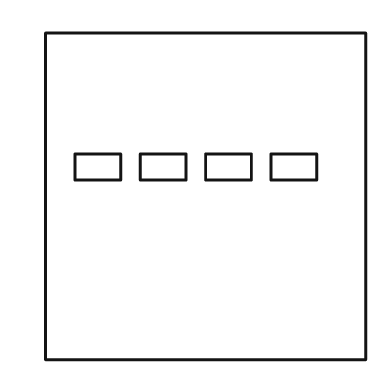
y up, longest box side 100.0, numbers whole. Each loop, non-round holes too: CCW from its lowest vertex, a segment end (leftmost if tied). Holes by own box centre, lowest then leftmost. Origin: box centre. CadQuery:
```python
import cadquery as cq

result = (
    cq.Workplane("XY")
    .moveTo(-49.0, -50.0)
    .lineTo(49.0, -50.0)
    .lineTo(49.0, 50.0)
    .lineTo(-49.0, 50.0)
    .close()
    .moveTo(-40.0, 5.0)
    .lineTo(-26.0, 5.0)
    .lineTo(-26.0, 13.0)
    .lineTo(-40.0, 13.0)
    .close()
    .moveTo(-20.0, 5.0)
    .lineTo(-6.0, 5.0)
    .lineTo(-6.0, 13.0)
    .lineTo(-20.0, 13.0)
    .close()
    .moveTo(0.0, 5.0)
    .lineTo(14.0, 5.0)
    .lineTo(14.0, 13.0)
    .lineTo(0.0, 13.0)
    .close()
    .moveTo(20.0, 5.0)
    .lineTo(34.0, 5.0)
    .lineTo(34.0, 13.0)
    .lineTo(20.0, 13.0)
    .close()
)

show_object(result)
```